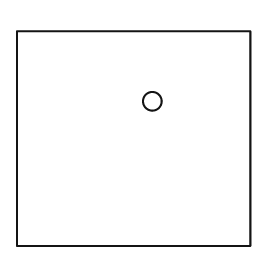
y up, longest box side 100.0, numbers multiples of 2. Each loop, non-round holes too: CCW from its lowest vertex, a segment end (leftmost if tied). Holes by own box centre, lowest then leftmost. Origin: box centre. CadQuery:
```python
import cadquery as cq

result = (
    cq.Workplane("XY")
    .moveTo(-50.0, -46.0)
    .lineTo(50.0, -46.0)
    .lineTo(50.0, 46.0)
    .lineTo(-50.0, 46.0)
    .close()
    .moveTo(8.0, 16.0)
    .circle(4.0)
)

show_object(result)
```